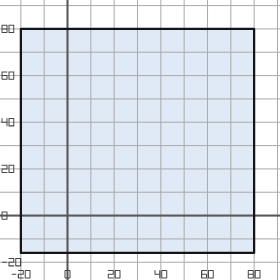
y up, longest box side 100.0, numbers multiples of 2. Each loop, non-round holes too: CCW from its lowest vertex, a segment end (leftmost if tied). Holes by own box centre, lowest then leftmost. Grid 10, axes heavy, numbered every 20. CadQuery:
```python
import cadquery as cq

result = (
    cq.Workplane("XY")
    .moveTo(-20.0, -16.0)
    .lineTo(80.0, -16.0)
    .lineTo(80.0, 80.0)
    .lineTo(-20.0, 80.0)
    .close()
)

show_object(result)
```